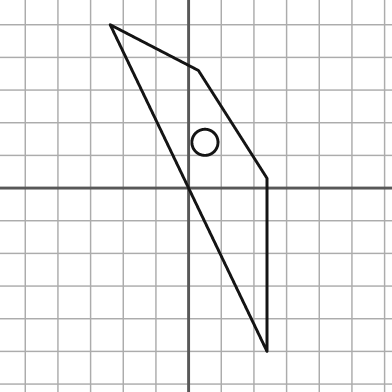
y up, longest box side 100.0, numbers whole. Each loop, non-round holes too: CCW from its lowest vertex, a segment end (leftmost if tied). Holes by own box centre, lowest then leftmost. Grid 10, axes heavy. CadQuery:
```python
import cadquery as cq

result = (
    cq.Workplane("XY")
    .moveTo(24.0, -50.0)
    .lineTo(24.0, 3.0)
    .lineTo(3.0, 36.0)
    .lineTo(-24.0, 50.0)
    .close()
    .moveTo(5.0, 14.0)
    .circle(4.0)
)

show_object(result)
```